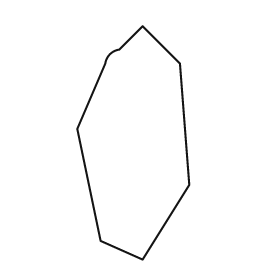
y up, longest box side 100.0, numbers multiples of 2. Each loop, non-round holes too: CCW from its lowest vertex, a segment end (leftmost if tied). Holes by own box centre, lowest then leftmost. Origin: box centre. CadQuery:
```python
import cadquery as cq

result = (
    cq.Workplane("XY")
    .moveTo(4.0, -50.0)
    .lineTo(24.0, -18.0)
    .lineTo(20.0, 34.0)
    .lineTo(4.0, 50.0)
    .lineTo(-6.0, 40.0)
    .threePointArc((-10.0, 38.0), (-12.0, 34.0))
    .lineTo(-24.0, 6.0)
    .lineTo(-14.0, -42.0)
    .close()
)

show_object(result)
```